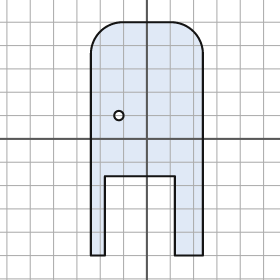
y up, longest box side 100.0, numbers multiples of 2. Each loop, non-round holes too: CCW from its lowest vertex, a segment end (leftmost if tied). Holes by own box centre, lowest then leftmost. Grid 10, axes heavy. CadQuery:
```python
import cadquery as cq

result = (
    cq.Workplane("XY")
    .moveTo(-24.0, -50.0)
    .lineTo(-18.0, -50.0)
    .lineTo(-18.0, -16.0)
    .lineTo(12.0, -16.0)
    .lineTo(12.0, -50.0)
    .lineTo(24.0, -50.0)
    .lineTo(24.0, 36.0)
    .threePointArc((20.0, 46.0), (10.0, 50.0))
    .lineTo(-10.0, 50.0)
    .threePointArc((-20.0, 46.0), (-24.0, 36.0))
    .close()
    .moveTo(-12.0, 10.0)
    .circle(2.0)
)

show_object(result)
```